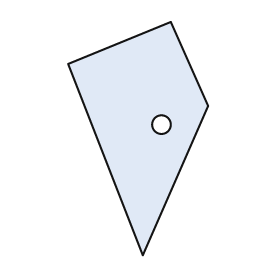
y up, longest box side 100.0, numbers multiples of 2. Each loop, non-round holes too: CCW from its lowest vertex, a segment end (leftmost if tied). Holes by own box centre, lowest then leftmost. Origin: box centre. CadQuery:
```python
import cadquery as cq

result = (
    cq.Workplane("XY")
    .moveTo(2.0, -50.0)
    .lineTo(30.0, 14.0)
    .lineTo(14.0, 50.0)
    .lineTo(-30.0, 32.0)
    .close()
    .moveTo(10.0, 6.0)
    .circle(4.0)
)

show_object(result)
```